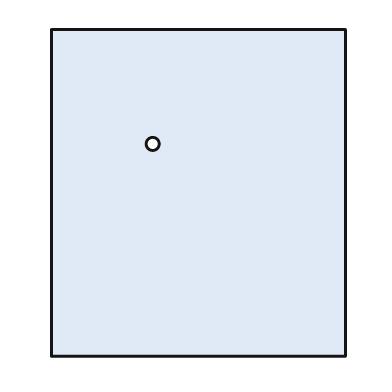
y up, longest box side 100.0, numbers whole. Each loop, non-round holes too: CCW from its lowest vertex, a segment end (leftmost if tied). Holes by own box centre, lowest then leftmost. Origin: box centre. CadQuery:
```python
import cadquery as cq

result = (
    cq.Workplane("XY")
    .moveTo(-45.0, -50.0)
    .lineTo(45.0, -50.0)
    .lineTo(45.0, 50.0)
    .lineTo(-45.0, 50.0)
    .close()
    .moveTo(-14.0, 15.0)
    .circle(2.0)
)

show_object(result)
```